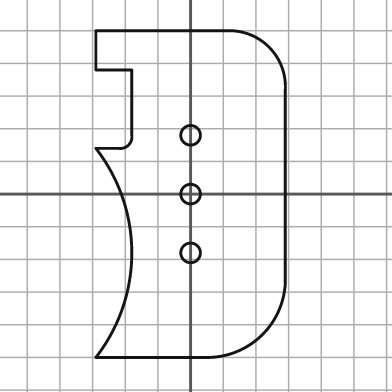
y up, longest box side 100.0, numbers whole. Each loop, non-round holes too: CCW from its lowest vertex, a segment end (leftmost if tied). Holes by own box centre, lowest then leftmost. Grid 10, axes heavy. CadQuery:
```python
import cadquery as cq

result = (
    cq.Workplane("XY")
    .moveTo(-29.0, -50.0)
    .lineTo(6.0, -50.0)
    .threePointArc((22.0, -43.0), (29.0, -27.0))
    .lineTo(29.0, 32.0)
    .threePointArc((24.0, 45.0), (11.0, 50.0))
    .lineTo(-29.0, 50.0)
    .lineTo(-29.0, 38.0)
    .lineTo(-18.0, 38.0)
    .lineTo(-18.0, 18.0)
    .threePointArc((-19.0, 15.0), (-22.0, 14.0))
    .lineTo(-29.0, 14.0)
    .threePointArc((-18.0, -18.0), (-29.0, -50.0))
    .close()
    .moveTo(0.0, -18.0)
    .circle(3.0)
    .moveTo(0.0, 0.0)
    .circle(3.0)
    .moveTo(0.0, 18.0)
    .circle(3.0)
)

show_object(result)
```